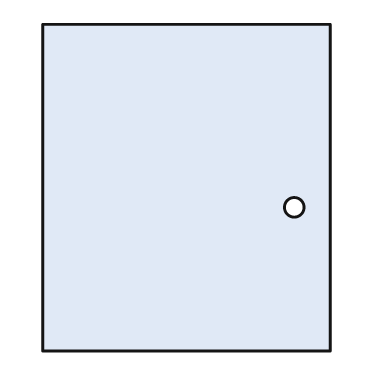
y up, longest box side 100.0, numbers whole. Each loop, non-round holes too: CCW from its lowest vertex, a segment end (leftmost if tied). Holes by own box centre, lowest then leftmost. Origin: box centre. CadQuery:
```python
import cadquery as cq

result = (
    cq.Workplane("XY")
    .moveTo(-44.0, -50.0)
    .lineTo(44.0, -50.0)
    .lineTo(44.0, 50.0)
    .lineTo(-44.0, 50.0)
    .close()
    .moveTo(33.0, -6.0)
    .circle(3.0)
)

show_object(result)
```